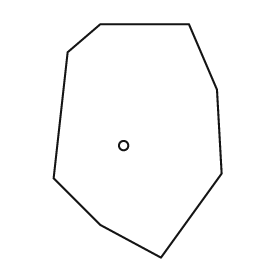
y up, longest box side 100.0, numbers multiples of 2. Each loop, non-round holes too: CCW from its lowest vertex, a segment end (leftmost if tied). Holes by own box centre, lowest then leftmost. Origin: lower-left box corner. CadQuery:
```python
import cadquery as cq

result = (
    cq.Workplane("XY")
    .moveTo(46.0, 0.0)
    .lineTo(72.0, 36.0)
    .lineTo(70.0, 72.0)
    .lineTo(58.0, 100.0)
    .lineTo(20.0, 100.0)
    .lineTo(6.0, 88.0)
    .lineTo(0.0, 34.0)
    .lineTo(20.0, 14.0)
    .close()
    .moveTo(30.0, 48.0)
    .circle(2.0)
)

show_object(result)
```